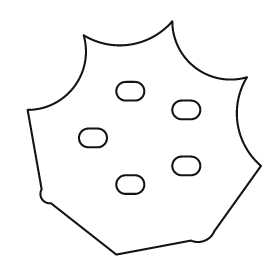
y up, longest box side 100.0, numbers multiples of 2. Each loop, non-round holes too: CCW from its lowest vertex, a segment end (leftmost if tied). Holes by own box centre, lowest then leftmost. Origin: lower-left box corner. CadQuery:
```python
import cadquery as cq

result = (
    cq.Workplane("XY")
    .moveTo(38.0, 0.0)
    .lineTo(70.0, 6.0)
    .threePointArc((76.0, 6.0), (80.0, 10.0))
    .lineTo(100.0, 38.0)
    .threePointArc((90.0, 56.0), (94.0, 76.0))
    .threePointArc((72.0, 80.0), (62.0, 100.0))
    .threePointArc((44.0, 90.0), (24.0, 94.0))
    .threePointArc((20.0, 72.0), (0.0, 62.0))
    .lineTo(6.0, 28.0)
    .threePointArc((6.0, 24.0), (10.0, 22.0))
    .close()
    .moveTo(42.0, 26.0)
    .lineTo(46.0, 26.0)
    .threePointArc((50.0, 30.0), (46.0, 34.0))
    .lineTo(42.0, 34.0)
    .threePointArc((38.0, 30.0), (42.0, 26.0))
    .close()
    .moveTo(66.0, 34.0)
    .lineTo(70.0, 34.0)
    .threePointArc((74.0, 38.0), (70.0, 42.0))
    .lineTo(66.0, 42.0)
    .threePointArc((62.0, 38.0), (66.0, 34.0))
    .close()
    .moveTo(26.0, 46.0)
    .lineTo(30.0, 46.0)
    .threePointArc((34.0, 50.0), (30.0, 54.0))
    .lineTo(26.0, 54.0)
    .threePointArc((22.0, 50.0), (26.0, 46.0))
    .close()
    .moveTo(66.0, 58.0)
    .lineTo(70.0, 58.0)
    .threePointArc((74.0, 62.0), (70.0, 66.0))
    .lineTo(66.0, 66.0)
    .threePointArc((62.0, 62.0), (66.0, 58.0))
    .close()
    .moveTo(42.0, 66.0)
    .lineTo(46.0, 66.0)
    .threePointArc((50.0, 70.0), (46.0, 74.0))
    .lineTo(42.0, 74.0)
    .threePointArc((38.0, 70.0), (42.0, 66.0))
    .close()
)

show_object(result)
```